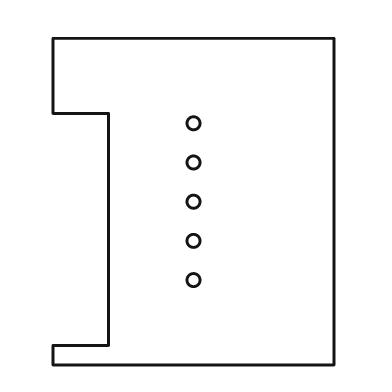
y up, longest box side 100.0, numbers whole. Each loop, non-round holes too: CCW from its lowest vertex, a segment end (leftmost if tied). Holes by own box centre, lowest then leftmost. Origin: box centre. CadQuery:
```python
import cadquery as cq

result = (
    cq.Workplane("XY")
    .moveTo(-43.0, -50.0)
    .lineTo(43.0, -50.0)
    .lineTo(43.0, 50.0)
    .lineTo(-43.0, 50.0)
    .lineTo(-43.0, 27.0)
    .lineTo(-26.0, 27.0)
    .lineTo(-26.0, -44.0)
    .lineTo(-43.0, -44.0)
    .close()
    .moveTo(0.0, -24.0)
    .circle(2.0)
    .moveTo(0.0, -12.0)
    .circle(2.0)
    .moveTo(0.0, 0.0)
    .circle(2.0)
    .moveTo(0.0, 12.0)
    .circle(2.0)
    .moveTo(0.0, 24.0)
    .circle(2.0)
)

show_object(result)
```